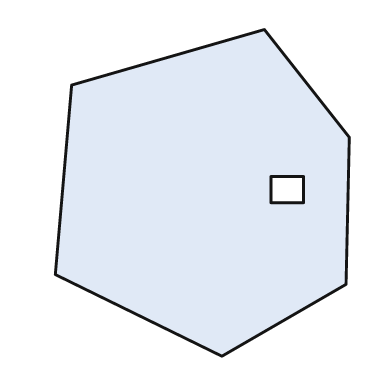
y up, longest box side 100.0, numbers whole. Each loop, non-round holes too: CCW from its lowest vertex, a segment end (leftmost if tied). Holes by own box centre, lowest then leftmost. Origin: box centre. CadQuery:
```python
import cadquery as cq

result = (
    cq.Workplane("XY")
    .moveTo(6.0, -50.0)
    .lineTo(44.0, -28.0)
    .lineTo(45.0, 17.0)
    .lineTo(19.0, 50.0)
    .lineTo(-40.0, 33.0)
    .lineTo(-45.0, -25.0)
    .close()
    .moveTo(21.0, -3.0)
    .lineTo(31.0, -3.0)
    .lineTo(31.0, 5.0)
    .lineTo(21.0, 5.0)
    .close()
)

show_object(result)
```